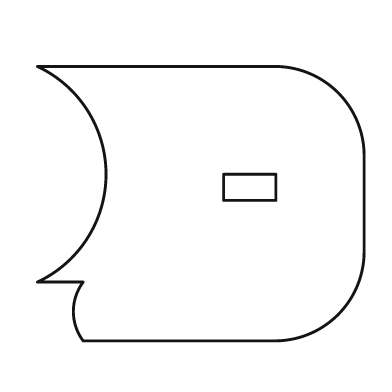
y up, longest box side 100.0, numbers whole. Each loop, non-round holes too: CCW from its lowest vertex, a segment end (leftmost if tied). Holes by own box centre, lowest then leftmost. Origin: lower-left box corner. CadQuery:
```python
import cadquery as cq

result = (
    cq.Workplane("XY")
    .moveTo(14.0, 0.0)
    .lineTo(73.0, 0.0)
    .threePointArc((92.0, 8.0), (100.0, 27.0))
    .lineTo(100.0, 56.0)
    .threePointArc((92.0, 76.0), (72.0, 84.0))
    .lineTo(0.0, 84.0)
    .threePointArc((21.0, 51.0), (0.0, 18.0))
    .lineTo(14.0, 18.0)
    .threePointArc((11.0, 9.0), (14.0, 0.0))
    .close()
    .moveTo(57.0, 43.0)
    .lineTo(73.0, 43.0)
    .lineTo(73.0, 51.0)
    .lineTo(57.0, 51.0)
    .close()
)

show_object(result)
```